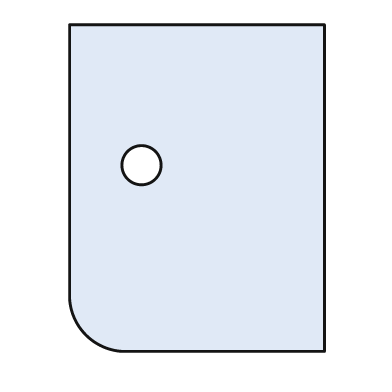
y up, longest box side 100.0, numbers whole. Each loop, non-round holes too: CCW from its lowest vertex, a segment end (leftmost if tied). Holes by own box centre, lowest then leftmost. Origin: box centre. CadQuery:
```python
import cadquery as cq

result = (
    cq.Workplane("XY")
    .moveTo(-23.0, -50.0)
    .lineTo(39.0, -50.0)
    .lineTo(39.0, 50.0)
    .lineTo(-39.0, 50.0)
    .lineTo(-39.0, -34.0)
    .threePointArc((-34.0, -45.0), (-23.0, -50.0))
    .close()
    .moveTo(-17.0, 7.0)
    .circle(6.0)
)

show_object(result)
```